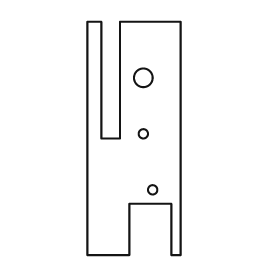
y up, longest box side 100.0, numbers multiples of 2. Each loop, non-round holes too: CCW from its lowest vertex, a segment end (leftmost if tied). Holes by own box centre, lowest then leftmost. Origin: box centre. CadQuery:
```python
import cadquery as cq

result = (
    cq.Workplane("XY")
    .moveTo(-20.0, -50.0)
    .lineTo(-2.0, -50.0)
    .lineTo(-2.0, -28.0)
    .lineTo(16.0, -28.0)
    .lineTo(16.0, -50.0)
    .lineTo(20.0, -50.0)
    .lineTo(20.0, 50.0)
    .lineTo(-6.0, 50.0)
    .lineTo(-6.0, 0.0)
    .lineTo(-14.0, 0.0)
    .lineTo(-14.0, 50.0)
    .lineTo(-20.0, 50.0)
    .close()
    .moveTo(8.0, -22.0)
    .circle(2.0)
    .moveTo(4.0, 2.0)
    .circle(2.0)
    .moveTo(4.0, 26.0)
    .circle(4.0)
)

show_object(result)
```